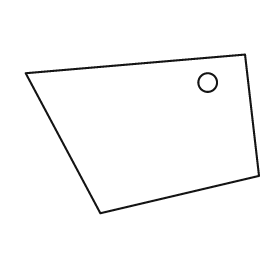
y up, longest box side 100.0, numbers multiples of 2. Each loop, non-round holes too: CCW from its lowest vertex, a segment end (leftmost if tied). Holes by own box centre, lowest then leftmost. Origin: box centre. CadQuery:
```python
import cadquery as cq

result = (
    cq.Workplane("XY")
    .moveTo(-18.0, -34.0)
    .lineTo(50.0, -18.0)
    .lineTo(44.0, 34.0)
    .lineTo(-50.0, 26.0)
    .close()
    .moveTo(28.0, 22.0)
    .circle(4.0)
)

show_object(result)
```